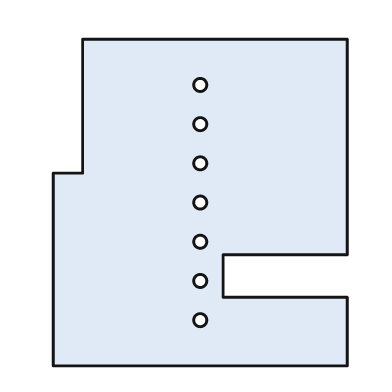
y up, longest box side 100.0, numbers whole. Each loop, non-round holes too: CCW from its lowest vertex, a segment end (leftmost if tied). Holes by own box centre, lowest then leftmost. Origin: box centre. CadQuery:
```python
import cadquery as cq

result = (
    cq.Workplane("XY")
    .moveTo(-45.0, -50.0)
    .lineTo(45.0, -50.0)
    .lineTo(45.0, -29.0)
    .lineTo(7.0, -29.0)
    .lineTo(7.0, -16.0)
    .lineTo(45.0, -16.0)
    .lineTo(45.0, 50.0)
    .lineTo(-36.0, 50.0)
    .lineTo(-36.0, 9.0)
    .lineTo(-45.0, 9.0)
    .close()
    .moveTo(0.0, -36.0)
    .circle(2.0)
    .moveTo(0.0, -24.0)
    .circle(2.0)
    .moveTo(0.0, -12.0)
    .circle(2.0)
    .moveTo(0.0, 0.0)
    .circle(2.0)
    .moveTo(0.0, 12.0)
    .circle(2.0)
    .moveTo(0.0, 24.0)
    .circle(2.0)
    .moveTo(0.0, 36.0)
    .circle(2.0)
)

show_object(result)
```